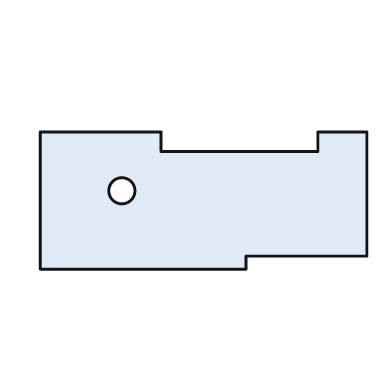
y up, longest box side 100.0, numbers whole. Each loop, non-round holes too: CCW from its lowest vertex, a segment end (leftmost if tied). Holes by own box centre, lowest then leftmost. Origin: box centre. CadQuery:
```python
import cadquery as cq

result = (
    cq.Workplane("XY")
    .moveTo(-50.0, -21.0)
    .lineTo(13.0, -21.0)
    .lineTo(13.0, -17.0)
    .lineTo(50.0, -17.0)
    .lineTo(50.0, 21.0)
    .lineTo(35.0, 21.0)
    .lineTo(35.0, 15.0)
    .lineTo(-13.0, 15.0)
    .lineTo(-13.0, 21.0)
    .lineTo(-50.0, 21.0)
    .close()
    .moveTo(-25.0, 3.0)
    .circle(4.0)
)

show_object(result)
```